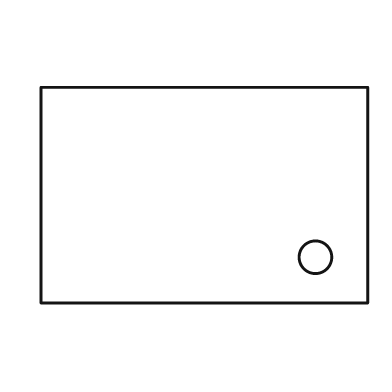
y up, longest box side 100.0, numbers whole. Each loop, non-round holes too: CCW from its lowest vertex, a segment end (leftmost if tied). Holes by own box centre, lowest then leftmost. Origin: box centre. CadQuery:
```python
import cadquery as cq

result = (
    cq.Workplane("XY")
    .moveTo(-50.0, -33.0)
    .lineTo(50.0, -33.0)
    .lineTo(50.0, 33.0)
    .lineTo(-50.0, 33.0)
    .close()
    .moveTo(34.0, -19.0)
    .circle(5.0)
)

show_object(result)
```